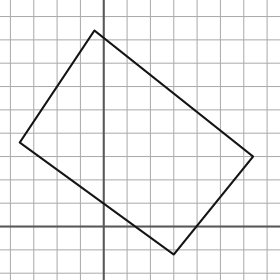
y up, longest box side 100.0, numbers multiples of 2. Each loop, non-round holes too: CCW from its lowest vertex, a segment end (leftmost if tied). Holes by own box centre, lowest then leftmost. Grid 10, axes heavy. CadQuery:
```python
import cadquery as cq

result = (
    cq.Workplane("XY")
    .moveTo(30.0, -12.0)
    .lineTo(64.0, 30.0)
    .lineTo(-4.0, 84.0)
    .lineTo(-36.0, 36.0)
    .close()
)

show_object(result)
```